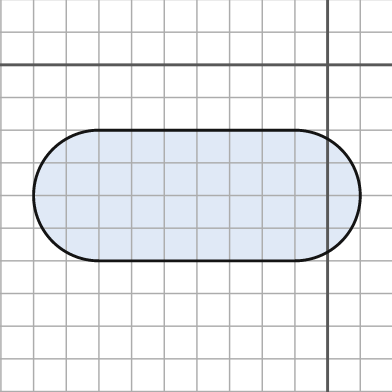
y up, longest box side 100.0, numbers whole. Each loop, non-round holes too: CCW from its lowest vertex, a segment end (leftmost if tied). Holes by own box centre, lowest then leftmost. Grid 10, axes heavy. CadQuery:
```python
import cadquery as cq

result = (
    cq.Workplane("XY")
    .moveTo(-70.0, -60.0)
    .lineTo(-10.0, -60.0)
    .threePointArc((10.0, -40.0), (-10.0, -20.0))
    .lineTo(-70.0, -20.0)
    .threePointArc((-90.0, -40.0), (-70.0, -60.0))
    .close()
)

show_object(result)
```